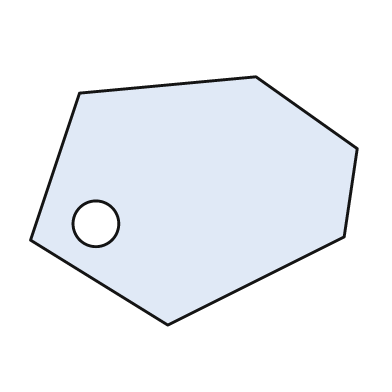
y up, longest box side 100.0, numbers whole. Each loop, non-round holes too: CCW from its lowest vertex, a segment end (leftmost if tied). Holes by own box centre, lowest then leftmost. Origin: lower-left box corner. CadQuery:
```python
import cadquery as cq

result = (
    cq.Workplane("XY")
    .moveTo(42.0, 0.0)
    .lineTo(96.0, 27.0)
    .lineTo(100.0, 54.0)
    .lineTo(69.0, 76.0)
    .lineTo(15.0, 71.0)
    .lineTo(0.0, 26.0)
    .close()
    .moveTo(20.0, 31.0)
    .circle(7.0)
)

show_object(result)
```